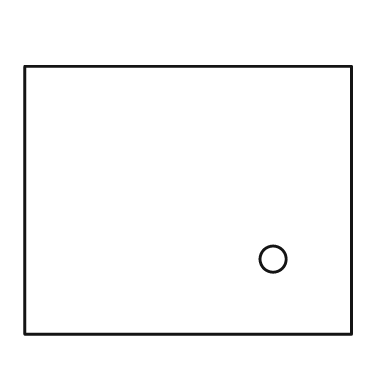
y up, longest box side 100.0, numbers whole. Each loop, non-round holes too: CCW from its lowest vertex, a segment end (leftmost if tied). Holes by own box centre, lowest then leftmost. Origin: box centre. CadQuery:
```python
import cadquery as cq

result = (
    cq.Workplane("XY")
    .moveTo(-50.0, -41.0)
    .lineTo(50.0, -41.0)
    .lineTo(50.0, 41.0)
    .lineTo(-50.0, 41.0)
    .close()
    .moveTo(26.0, -18.0)
    .circle(4.0)
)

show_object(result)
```